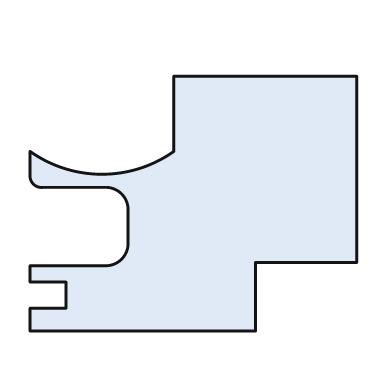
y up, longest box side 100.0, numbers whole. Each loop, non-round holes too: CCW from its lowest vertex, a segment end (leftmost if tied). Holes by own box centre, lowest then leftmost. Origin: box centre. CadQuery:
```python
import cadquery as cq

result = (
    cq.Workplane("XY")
    .moveTo(-50.0, -39.0)
    .lineTo(19.0, -39.0)
    .lineTo(19.0, -18.0)
    .lineTo(50.0, -18.0)
    .lineTo(50.0, 39.0)
    .lineTo(-6.0, 39.0)
    .lineTo(-6.0, 16.0)
    .threePointArc((-28.0, 9.0), (-50.0, 16.0))
    .lineTo(-50.0, 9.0)
    .threePointArc((-49.0, 6.0), (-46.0, 5.0))
    .lineTo(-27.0, 5.0)
    .threePointArc((-22.0, 3.0), (-20.0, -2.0))
    .lineTo(-20.0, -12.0)
    .threePointArc((-22.0, -17.0), (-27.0, -19.0))
    .lineTo(-50.0, -19.0)
    .lineTo(-50.0, -24.0)
    .lineTo(-39.0, -24.0)
    .lineTo(-39.0, -32.0)
    .lineTo(-50.0, -32.0)
    .close()
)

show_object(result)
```